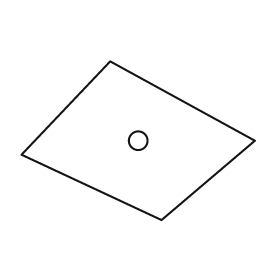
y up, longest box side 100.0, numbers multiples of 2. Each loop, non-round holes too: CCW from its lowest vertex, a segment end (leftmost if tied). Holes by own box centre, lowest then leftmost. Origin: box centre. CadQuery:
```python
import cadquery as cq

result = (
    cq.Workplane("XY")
    .moveTo(10.0, -34.0)
    .lineTo(50.0, 0.0)
    .lineTo(-12.0, 34.0)
    .lineTo(-50.0, -6.0)
    .close()
    .moveTo(0.0, 0.0)
    .circle(4.0)
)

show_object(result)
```